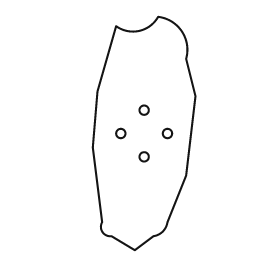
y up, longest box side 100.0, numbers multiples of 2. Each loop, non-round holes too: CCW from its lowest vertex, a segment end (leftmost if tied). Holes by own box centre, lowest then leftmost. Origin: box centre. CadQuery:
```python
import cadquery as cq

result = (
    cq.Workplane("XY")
    .moveTo(-4.0, -50.0)
    .lineTo(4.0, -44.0)
    .threePointArc((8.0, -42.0), (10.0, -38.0))
    .lineTo(18.0, -18.0)
    .lineTo(22.0, 16.0)
    .lineTo(18.0, 32.0)
    .threePointArc((16.0, 44.0), (6.0, 50.0))
    .threePointArc((-2.0, 44.0), (-12.0, 46.0))
    .lineTo(-20.0, 18.0)
    .lineTo(-22.0, -6.0)
    .lineTo(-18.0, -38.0)
    .threePointArc((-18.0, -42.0), (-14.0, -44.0))
    .close()
    .moveTo(0.0, -10.0)
    .circle(2.0)
    .moveTo(-10.0, 0.0)
    .circle(2.0)
    .moveTo(10.0, 0.0)
    .circle(2.0)
    .moveTo(0.0, 10.0)
    .circle(2.0)
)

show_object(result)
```